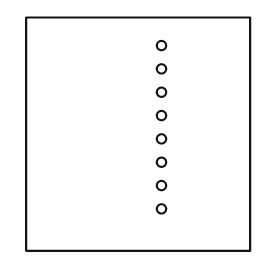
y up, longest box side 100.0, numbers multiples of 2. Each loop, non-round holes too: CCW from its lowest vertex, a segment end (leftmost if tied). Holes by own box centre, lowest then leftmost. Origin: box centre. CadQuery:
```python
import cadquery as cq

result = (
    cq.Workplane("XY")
    .moveTo(-48.0, -50.0)
    .lineTo(48.0, -50.0)
    .lineTo(48.0, 50.0)
    .lineTo(-48.0, 50.0)
    .close()
    .moveTo(10.0, -32.0)
    .circle(2.0)
    .moveTo(10.0, -22.0)
    .circle(2.0)
    .moveTo(10.0, -12.0)
    .circle(2.0)
    .moveTo(10.0, -2.0)
    .circle(2.0)
    .moveTo(10.0, 8.0)
    .circle(2.0)
    .moveTo(10.0, 18.0)
    .circle(2.0)
    .moveTo(10.0, 28.0)
    .circle(2.0)
    .moveTo(10.0, 38.0)
    .circle(2.0)
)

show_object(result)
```